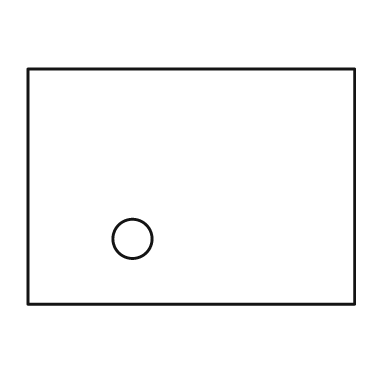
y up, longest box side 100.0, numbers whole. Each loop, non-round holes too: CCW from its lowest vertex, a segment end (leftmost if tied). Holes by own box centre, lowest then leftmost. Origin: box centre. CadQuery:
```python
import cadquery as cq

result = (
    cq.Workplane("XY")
    .moveTo(-50.0, -36.0)
    .lineTo(50.0, -36.0)
    .lineTo(50.0, 36.0)
    .lineTo(-50.0, 36.0)
    .close()
    .moveTo(-18.0, -16.0)
    .circle(6.0)
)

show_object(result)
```